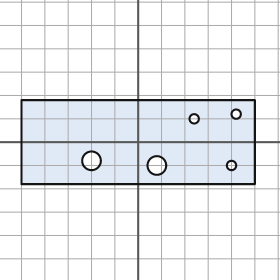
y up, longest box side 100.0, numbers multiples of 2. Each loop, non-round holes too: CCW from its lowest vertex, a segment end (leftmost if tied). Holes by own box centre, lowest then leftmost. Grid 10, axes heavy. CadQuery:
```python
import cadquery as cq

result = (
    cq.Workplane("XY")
    .moveTo(-50.0, -18.0)
    .lineTo(50.0, -18.0)
    .lineTo(50.0, 18.0)
    .lineTo(-50.0, 18.0)
    .close()
    .moveTo(8.0, -10.0)
    .circle(4.0)
    .moveTo(40.0, -10.0)
    .circle(2.0)
    .moveTo(-20.0, -8.0)
    .circle(4.0)
    .moveTo(24.0, 10.0)
    .circle(2.0)
    .moveTo(42.0, 12.0)
    .circle(2.0)
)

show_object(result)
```